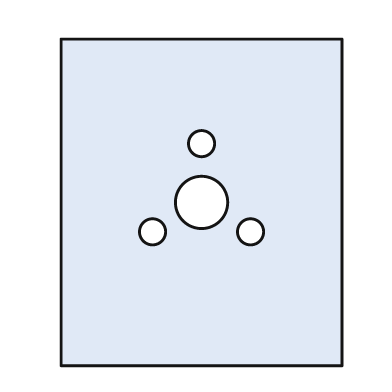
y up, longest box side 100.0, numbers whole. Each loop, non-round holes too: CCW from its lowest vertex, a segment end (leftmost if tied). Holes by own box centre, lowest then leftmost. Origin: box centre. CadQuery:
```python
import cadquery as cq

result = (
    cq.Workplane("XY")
    .moveTo(-43.0, -50.0)
    .lineTo(43.0, -50.0)
    .lineTo(43.0, 50.0)
    .lineTo(-43.0, 50.0)
    .close()
    .moveTo(-15.0, -9.0)
    .circle(4.0)
    .moveTo(15.0, -9.0)
    .circle(4.0)
    .moveTo(0.0, 0.0)
    .circle(8.0)
    .moveTo(0.0, 18.0)
    .circle(4.0)
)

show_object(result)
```